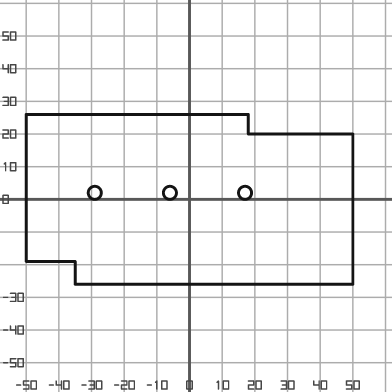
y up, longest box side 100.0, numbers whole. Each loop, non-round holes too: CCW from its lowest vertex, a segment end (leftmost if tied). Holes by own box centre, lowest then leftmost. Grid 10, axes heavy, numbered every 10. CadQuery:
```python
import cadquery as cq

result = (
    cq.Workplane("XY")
    .moveTo(-35.0, -26.0)
    .lineTo(50.0, -26.0)
    .lineTo(50.0, 20.0)
    .lineTo(18.0, 20.0)
    .lineTo(18.0, 26.0)
    .lineTo(-50.0, 26.0)
    .lineTo(-50.0, -19.0)
    .lineTo(-35.0, -19.0)
    .close()
    .moveTo(-29.0, 2.0)
    .circle(2.0)
    .moveTo(-6.0, 2.0)
    .circle(2.0)
    .moveTo(17.0, 2.0)
    .circle(2.0)
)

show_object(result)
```